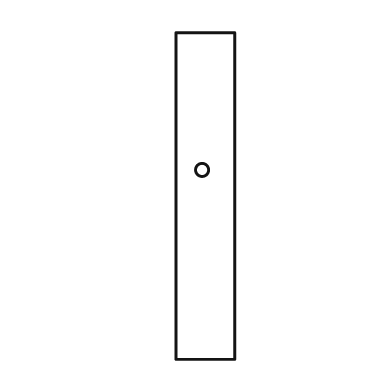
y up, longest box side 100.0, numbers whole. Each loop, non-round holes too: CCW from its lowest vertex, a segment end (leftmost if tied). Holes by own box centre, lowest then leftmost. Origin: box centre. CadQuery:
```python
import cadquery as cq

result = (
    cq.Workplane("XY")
    .moveTo(-9.0, -50.0)
    .lineTo(9.0, -50.0)
    .lineTo(9.0, 50.0)
    .lineTo(-9.0, 50.0)
    .close()
    .moveTo(-1.0, 8.0)
    .circle(2.0)
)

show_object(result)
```